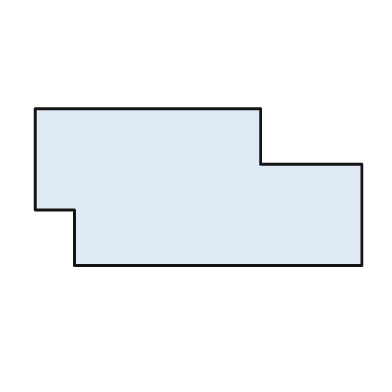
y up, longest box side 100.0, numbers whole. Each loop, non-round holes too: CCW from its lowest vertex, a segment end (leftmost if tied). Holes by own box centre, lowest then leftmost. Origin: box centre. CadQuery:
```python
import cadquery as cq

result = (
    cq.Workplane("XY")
    .moveTo(-38.0, -24.0)
    .lineTo(50.0, -24.0)
    .lineTo(50.0, 7.0)
    .lineTo(19.0, 7.0)
    .lineTo(19.0, 24.0)
    .lineTo(-50.0, 24.0)
    .lineTo(-50.0, -7.0)
    .lineTo(-38.0, -7.0)
    .close()
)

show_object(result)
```